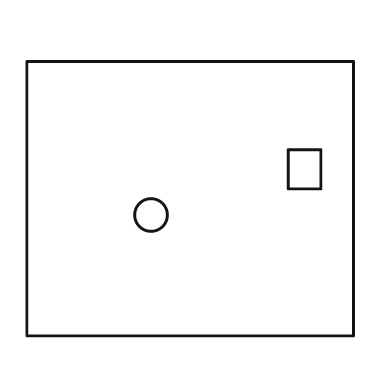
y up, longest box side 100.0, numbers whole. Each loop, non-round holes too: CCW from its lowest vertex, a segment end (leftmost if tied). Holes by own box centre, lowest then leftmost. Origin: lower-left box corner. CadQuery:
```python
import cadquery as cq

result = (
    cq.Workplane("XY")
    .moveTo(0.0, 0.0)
    .lineTo(100.0, 0.0)
    .lineTo(100.0, 84.0)
    .lineTo(0.0, 84.0)
    .close()
    .moveTo(38.0, 37.0)
    .circle(5.0)
    .moveTo(80.0, 45.0)
    .lineTo(90.0, 45.0)
    .lineTo(90.0, 57.0)
    .lineTo(80.0, 57.0)
    .close()
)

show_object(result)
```